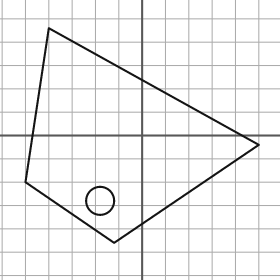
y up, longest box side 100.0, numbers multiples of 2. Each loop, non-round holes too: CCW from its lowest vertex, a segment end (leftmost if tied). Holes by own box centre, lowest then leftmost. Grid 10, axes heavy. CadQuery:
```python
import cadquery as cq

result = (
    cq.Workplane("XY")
    .moveTo(-12.0, -46.0)
    .lineTo(50.0, -4.0)
    .lineTo(-40.0, 46.0)
    .lineTo(-50.0, -20.0)
    .close()
    .moveTo(-18.0, -28.0)
    .circle(6.0)
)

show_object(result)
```